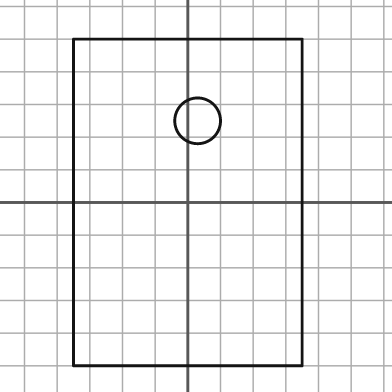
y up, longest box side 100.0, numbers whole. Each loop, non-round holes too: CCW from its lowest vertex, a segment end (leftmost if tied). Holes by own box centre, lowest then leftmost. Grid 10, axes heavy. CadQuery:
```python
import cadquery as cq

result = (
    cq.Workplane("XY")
    .moveTo(-35.0, -50.0)
    .lineTo(35.0, -50.0)
    .lineTo(35.0, 50.0)
    .lineTo(-35.0, 50.0)
    .close()
    .moveTo(3.0, 25.0)
    .circle(7.0)
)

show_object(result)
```